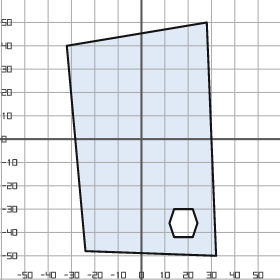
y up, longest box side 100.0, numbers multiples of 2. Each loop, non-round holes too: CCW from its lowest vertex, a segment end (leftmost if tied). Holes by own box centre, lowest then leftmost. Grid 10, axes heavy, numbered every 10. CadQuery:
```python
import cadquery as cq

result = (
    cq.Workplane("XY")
    .moveTo(32.0, -50.0)
    .lineTo(28.0, 50.0)
    .lineTo(-32.0, 40.0)
    .lineTo(-24.0, -48.0)
    .close()
    .moveTo(14.0, -42.0)
    .lineTo(22.0, -42.0)
    .lineTo(24.0, -36.0)
    .lineTo(22.0, -30.0)
    .lineTo(14.0, -30.0)
    .lineTo(12.0, -36.0)
    .close()
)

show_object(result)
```